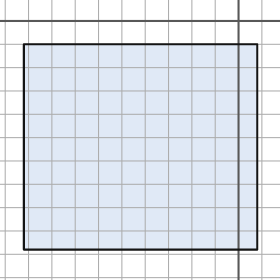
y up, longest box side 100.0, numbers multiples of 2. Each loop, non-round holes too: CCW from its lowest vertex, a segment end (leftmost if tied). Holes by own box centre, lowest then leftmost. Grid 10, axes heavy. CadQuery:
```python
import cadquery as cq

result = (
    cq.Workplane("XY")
    .moveTo(-92.0, -98.0)
    .lineTo(8.0, -98.0)
    .lineTo(8.0, -10.0)
    .lineTo(-92.0, -10.0)
    .close()
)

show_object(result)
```